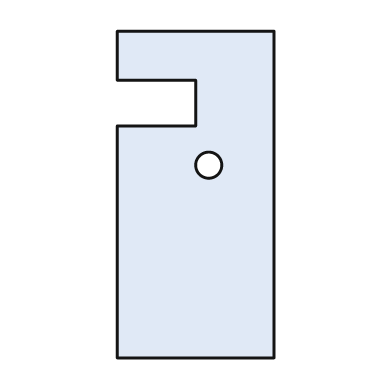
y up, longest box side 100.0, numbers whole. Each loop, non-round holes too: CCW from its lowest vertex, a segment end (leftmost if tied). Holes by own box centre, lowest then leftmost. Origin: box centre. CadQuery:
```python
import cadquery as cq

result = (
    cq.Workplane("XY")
    .moveTo(-24.0, -50.0)
    .lineTo(24.0, -50.0)
    .lineTo(24.0, 50.0)
    .lineTo(-24.0, 50.0)
    .lineTo(-24.0, 35.0)
    .lineTo(0.0, 35.0)
    .lineTo(0.0, 21.0)
    .lineTo(-24.0, 21.0)
    .close()
    .moveTo(4.0, 9.0)
    .circle(4.0)
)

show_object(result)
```